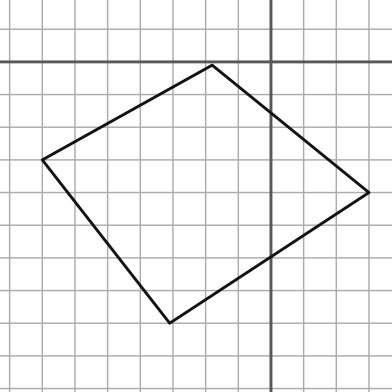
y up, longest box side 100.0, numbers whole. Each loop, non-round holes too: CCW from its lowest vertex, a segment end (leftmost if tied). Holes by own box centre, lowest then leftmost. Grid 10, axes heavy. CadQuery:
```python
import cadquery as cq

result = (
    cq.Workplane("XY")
    .moveTo(-31.0, -80.0)
    .lineTo(30.0, -40.0)
    .lineTo(-18.0, -1.0)
    .lineTo(-70.0, -30.0)
    .close()
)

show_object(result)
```